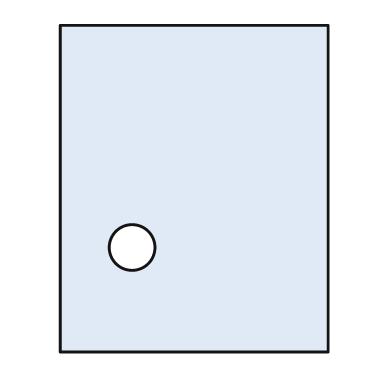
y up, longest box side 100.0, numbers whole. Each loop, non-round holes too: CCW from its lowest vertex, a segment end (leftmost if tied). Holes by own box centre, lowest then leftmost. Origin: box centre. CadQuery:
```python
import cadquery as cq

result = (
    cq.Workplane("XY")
    .moveTo(-41.0, -50.0)
    .lineTo(41.0, -50.0)
    .lineTo(41.0, 50.0)
    .lineTo(-41.0, 50.0)
    .close()
    .moveTo(-19.0, -18.0)
    .circle(7.0)
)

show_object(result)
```